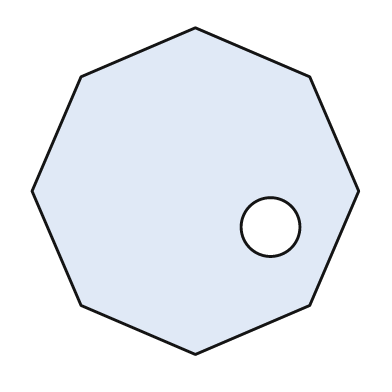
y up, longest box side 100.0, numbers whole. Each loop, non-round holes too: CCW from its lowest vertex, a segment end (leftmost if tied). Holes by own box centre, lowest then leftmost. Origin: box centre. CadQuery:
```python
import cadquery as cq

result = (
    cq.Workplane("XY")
    .moveTo(0.0, -50.0)
    .lineTo(35.0, -35.0)
    .lineTo(50.0, 0.0)
    .lineTo(35.0, 35.0)
    .lineTo(0.0, 50.0)
    .lineTo(-35.0, 35.0)
    .lineTo(-50.0, 0.0)
    .lineTo(-35.0, -35.0)
    .close()
    .moveTo(23.0, -11.0)
    .circle(9.0)
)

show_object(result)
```